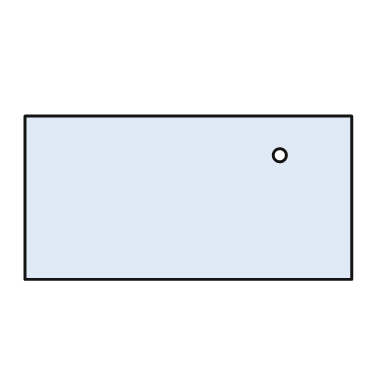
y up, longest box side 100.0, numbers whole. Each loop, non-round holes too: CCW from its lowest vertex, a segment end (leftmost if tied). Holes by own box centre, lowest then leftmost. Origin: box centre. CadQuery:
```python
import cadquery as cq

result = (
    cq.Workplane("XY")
    .moveTo(-50.0, -25.0)
    .lineTo(50.0, -25.0)
    .lineTo(50.0, 25.0)
    .lineTo(-50.0, 25.0)
    .close()
    .moveTo(28.0, 13.0)
    .circle(2.0)
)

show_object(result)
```